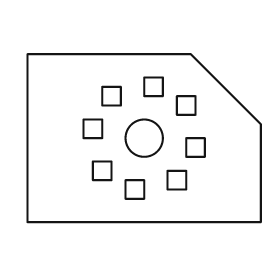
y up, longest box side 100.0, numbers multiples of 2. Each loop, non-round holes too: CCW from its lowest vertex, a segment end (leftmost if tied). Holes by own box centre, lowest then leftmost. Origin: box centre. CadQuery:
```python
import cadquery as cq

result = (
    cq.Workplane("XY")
    .moveTo(-50.0, -36.0)
    .lineTo(50.0, -36.0)
    .lineTo(50.0, 6.0)
    .lineTo(20.0, 36.0)
    .lineTo(-50.0, 36.0)
    .close()
    .moveTo(-8.0, -26.0)
    .lineTo(0.0, -26.0)
    .lineTo(0.0, -18.0)
    .lineTo(-8.0, -18.0)
    .close()
    .moveTo(10.0, -22.0)
    .lineTo(18.0, -22.0)
    .lineTo(18.0, -14.0)
    .lineTo(10.0, -14.0)
    .close()
    .moveTo(-22.0, -18.0)
    .lineTo(-14.0, -18.0)
    .lineTo(-14.0, -10.0)
    .lineTo(-22.0, -10.0)
    .close()
    .moveTo(18.0, -8.0)
    .lineTo(26.0, -8.0)
    .lineTo(26.0, 0.0)
    .lineTo(18.0, 0.0)
    .close()
    .moveTo(0.0, 0.0)
    .circle(8.0)
    .moveTo(-26.0, 0.0)
    .lineTo(-18.0, 0.0)
    .lineTo(-18.0, 8.0)
    .lineTo(-26.0, 8.0)
    .close()
    .moveTo(14.0, 10.0)
    .lineTo(22.0, 10.0)
    .lineTo(22.0, 18.0)
    .lineTo(14.0, 18.0)
    .close()
    .moveTo(-18.0, 14.0)
    .lineTo(-10.0, 14.0)
    .lineTo(-10.0, 22.0)
    .lineTo(-18.0, 22.0)
    .close()
    .moveTo(0.0, 18.0)
    .lineTo(8.0, 18.0)
    .lineTo(8.0, 26.0)
    .lineTo(0.0, 26.0)
    .close()
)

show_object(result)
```